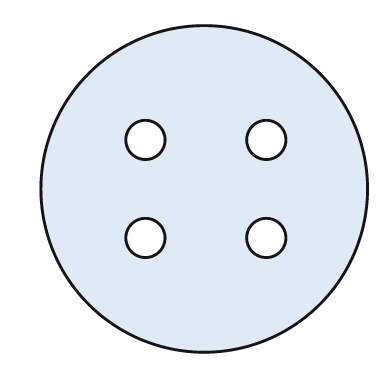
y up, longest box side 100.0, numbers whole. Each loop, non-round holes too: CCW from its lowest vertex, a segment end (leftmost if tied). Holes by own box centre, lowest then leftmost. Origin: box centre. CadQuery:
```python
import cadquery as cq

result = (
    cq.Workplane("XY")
    .moveTo(0.0, 0.0)
    .circle(50.0)
    .moveTo(-18.0, -15.0)
    .circle(6.0)
    .moveTo(19.0, -15.0)
    .circle(6.0)
    .moveTo(-18.0, 15.0)
    .circle(6.0)
    .moveTo(19.0, 15.0)
    .circle(6.0)
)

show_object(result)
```